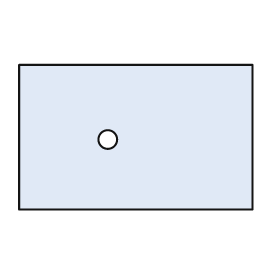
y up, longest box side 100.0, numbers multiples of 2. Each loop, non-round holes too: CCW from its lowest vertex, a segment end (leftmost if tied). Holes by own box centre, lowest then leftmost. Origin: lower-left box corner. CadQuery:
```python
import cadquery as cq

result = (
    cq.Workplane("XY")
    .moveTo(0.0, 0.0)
    .lineTo(100.0, 0.0)
    .lineTo(100.0, 62.0)
    .lineTo(0.0, 62.0)
    .close()
    .moveTo(38.0, 30.0)
    .circle(4.0)
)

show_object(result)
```